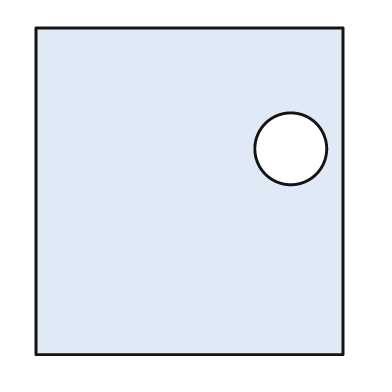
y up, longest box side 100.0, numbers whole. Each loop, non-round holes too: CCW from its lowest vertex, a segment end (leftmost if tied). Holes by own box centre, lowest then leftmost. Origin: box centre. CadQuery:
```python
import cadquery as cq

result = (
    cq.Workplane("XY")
    .moveTo(-47.0, -50.0)
    .lineTo(47.0, -50.0)
    .lineTo(47.0, 50.0)
    .lineTo(-47.0, 50.0)
    .close()
    .moveTo(31.0, 13.0)
    .circle(11.0)
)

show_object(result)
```